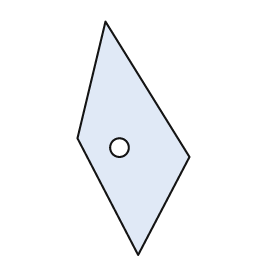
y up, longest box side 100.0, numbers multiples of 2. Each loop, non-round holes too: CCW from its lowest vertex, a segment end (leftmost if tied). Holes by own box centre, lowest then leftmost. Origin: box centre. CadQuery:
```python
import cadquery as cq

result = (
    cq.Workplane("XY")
    .moveTo(2.0, -50.0)
    .lineTo(24.0, -8.0)
    .lineTo(-12.0, 50.0)
    .lineTo(-24.0, 0.0)
    .close()
    .moveTo(-6.0, -4.0)
    .circle(4.0)
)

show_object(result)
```